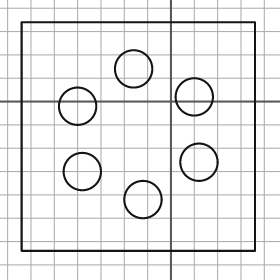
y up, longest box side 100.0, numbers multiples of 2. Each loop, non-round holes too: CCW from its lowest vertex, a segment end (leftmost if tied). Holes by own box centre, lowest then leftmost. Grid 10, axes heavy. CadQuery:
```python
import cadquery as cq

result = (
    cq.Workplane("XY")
    .moveTo(-64.0, -64.0)
    .lineTo(36.0, -64.0)
    .lineTo(36.0, 34.0)
    .lineTo(-64.0, 34.0)
    .close()
    .moveTo(-12.0, -42.0)
    .circle(8.0)
    .moveTo(-38.0, -30.0)
    .circle(8.0)
    .moveTo(12.0, -26.0)
    .circle(8.0)
    .moveTo(-40.0, -2.0)
    .circle(8.0)
    .moveTo(10.0, 2.0)
    .circle(8.0)
    .moveTo(-16.0, 14.0)
    .circle(8.0)
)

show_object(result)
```